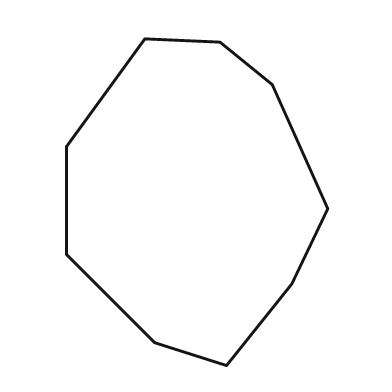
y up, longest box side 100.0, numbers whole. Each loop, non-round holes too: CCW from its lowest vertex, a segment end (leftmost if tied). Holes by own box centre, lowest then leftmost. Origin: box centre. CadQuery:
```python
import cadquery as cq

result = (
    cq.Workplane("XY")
    .moveTo(9.0, -50.0)
    .lineTo(29.0, -25.0)
    .lineTo(40.0, -2.0)
    .lineTo(23.0, 36.0)
    .lineTo(7.0, 49.0)
    .lineTo(-16.0, 50.0)
    .lineTo(-40.0, 17.0)
    .lineTo(-40.0, -16.0)
    .lineTo(-13.0, -43.0)
    .close()
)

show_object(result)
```